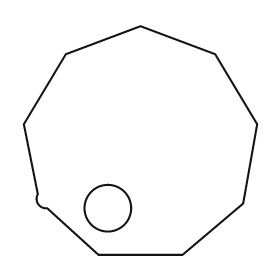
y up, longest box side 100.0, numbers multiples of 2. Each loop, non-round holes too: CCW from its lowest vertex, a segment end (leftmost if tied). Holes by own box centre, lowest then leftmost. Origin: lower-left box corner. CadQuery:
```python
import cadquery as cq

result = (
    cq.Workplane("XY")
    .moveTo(32.0, 0.0)
    .lineTo(68.0, 0.0)
    .lineTo(94.0, 22.0)
    .lineTo(100.0, 56.0)
    .lineTo(82.0, 86.0)
    .lineTo(50.0, 98.0)
    .lineTo(18.0, 86.0)
    .lineTo(0.0, 56.0)
    .lineTo(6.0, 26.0)
    .threePointArc((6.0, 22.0), (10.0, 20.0))
    .close()
    .moveTo(36.0, 20.0)
    .circle(10.0)
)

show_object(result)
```